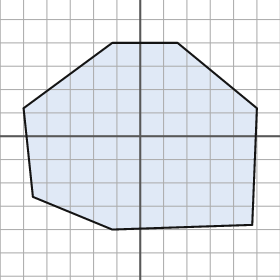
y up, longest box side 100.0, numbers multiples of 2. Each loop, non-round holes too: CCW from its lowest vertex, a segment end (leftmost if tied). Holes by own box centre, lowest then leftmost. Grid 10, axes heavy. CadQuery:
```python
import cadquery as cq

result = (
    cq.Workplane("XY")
    .moveTo(-12.0, -40.0)
    .lineTo(48.0, -38.0)
    .lineTo(50.0, 12.0)
    .lineTo(16.0, 40.0)
    .lineTo(-12.0, 40.0)
    .lineTo(-50.0, 12.0)
    .lineTo(-46.0, -26.0)
    .close()
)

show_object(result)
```